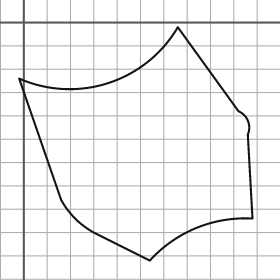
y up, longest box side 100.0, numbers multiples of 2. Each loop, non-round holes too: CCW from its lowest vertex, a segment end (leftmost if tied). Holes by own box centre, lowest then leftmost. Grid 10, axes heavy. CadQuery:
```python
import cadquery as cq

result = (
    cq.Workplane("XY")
    .moveTo(54.0, -102.0)
    .threePointArc((74.0, -88.0), (98.0, -84.0))
    .lineTo(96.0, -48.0)
    .threePointArc((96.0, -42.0), (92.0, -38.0))
    .lineTo(66.0, -2.0)
    .threePointArc((36.0, -26.0), (-2.0, -24.0))
    .lineTo(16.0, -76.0)
    .threePointArc((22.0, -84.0), (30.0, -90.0))
    .close()
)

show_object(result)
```